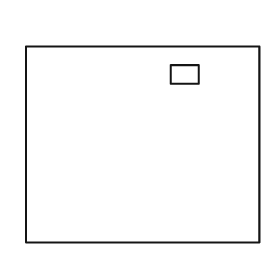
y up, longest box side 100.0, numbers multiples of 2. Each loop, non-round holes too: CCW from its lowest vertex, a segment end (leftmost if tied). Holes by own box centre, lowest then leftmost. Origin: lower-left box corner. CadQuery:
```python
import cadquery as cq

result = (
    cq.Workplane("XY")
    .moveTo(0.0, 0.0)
    .lineTo(100.0, 0.0)
    .lineTo(100.0, 84.0)
    .lineTo(0.0, 84.0)
    .close()
    .moveTo(62.0, 68.0)
    .lineTo(74.0, 68.0)
    .lineTo(74.0, 76.0)
    .lineTo(62.0, 76.0)
    .close()
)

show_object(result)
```